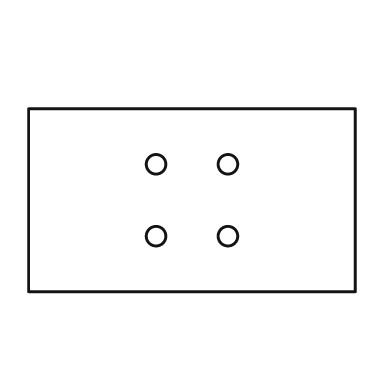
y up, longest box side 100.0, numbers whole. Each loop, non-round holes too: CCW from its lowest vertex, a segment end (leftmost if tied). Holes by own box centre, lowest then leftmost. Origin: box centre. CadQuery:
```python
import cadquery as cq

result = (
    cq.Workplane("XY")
    .moveTo(-50.0, -28.0)
    .lineTo(50.0, -28.0)
    .lineTo(50.0, 28.0)
    .lineTo(-50.0, 28.0)
    .close()
    .moveTo(-11.0, -11.0)
    .circle(3.0)
    .moveTo(11.0, -11.0)
    .circle(3.0)
    .moveTo(-11.0, 11.0)
    .circle(3.0)
    .moveTo(11.0, 11.0)
    .circle(3.0)
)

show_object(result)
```